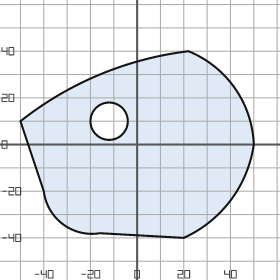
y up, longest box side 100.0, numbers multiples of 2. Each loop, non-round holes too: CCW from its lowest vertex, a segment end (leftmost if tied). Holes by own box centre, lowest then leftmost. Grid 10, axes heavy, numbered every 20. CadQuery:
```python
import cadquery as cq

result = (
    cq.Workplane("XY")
    .moveTo(20.0, -40.0)
    .threePointArc((40.0, -24.0), (50.0, 0.0))
    .threePointArc((42.0, 24.0), (22.0, 40.0))
    .threePointArc((-16.0, 30.0), (-50.0, 10.0))
    .lineTo(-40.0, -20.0)
    .threePointArc((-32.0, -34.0), (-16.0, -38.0))
    .close()
    .moveTo(-12.0, 10.0)
    .circle(8.0)
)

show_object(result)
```